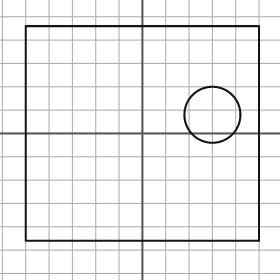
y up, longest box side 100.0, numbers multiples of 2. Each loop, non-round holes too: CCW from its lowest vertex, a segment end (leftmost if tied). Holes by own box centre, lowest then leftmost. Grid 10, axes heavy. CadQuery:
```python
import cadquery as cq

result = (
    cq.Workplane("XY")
    .moveTo(-50.0, -46.0)
    .lineTo(50.0, -46.0)
    .lineTo(50.0, 46.0)
    .lineTo(-50.0, 46.0)
    .close()
    .moveTo(30.0, 8.0)
    .circle(12.0)
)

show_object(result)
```